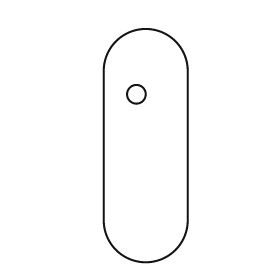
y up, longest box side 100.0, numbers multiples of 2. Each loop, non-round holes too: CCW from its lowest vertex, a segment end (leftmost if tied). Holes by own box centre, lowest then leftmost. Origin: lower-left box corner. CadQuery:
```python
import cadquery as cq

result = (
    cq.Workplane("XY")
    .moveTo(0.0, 18.0)
    .threePointArc((18.0, 0.0), (36.0, 18.0))
    .lineTo(36.0, 82.0)
    .threePointArc((18.0, 100.0), (0.0, 82.0))
    .close()
    .moveTo(14.0, 72.0)
    .circle(4.0)
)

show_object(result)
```